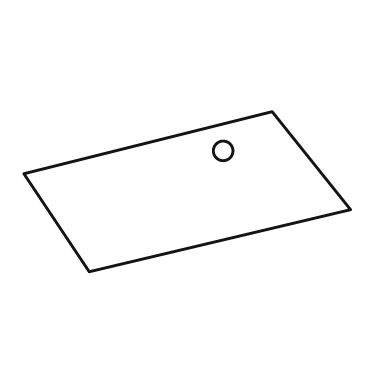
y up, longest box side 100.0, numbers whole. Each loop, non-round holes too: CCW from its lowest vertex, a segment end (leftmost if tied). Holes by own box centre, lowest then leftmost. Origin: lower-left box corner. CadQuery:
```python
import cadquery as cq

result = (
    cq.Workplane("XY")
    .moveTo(20.0, 0.0)
    .lineTo(100.0, 19.0)
    .lineTo(76.0, 49.0)
    .lineTo(0.0, 30.0)
    .close()
    .moveTo(61.0, 37.0)
    .circle(3.0)
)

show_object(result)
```